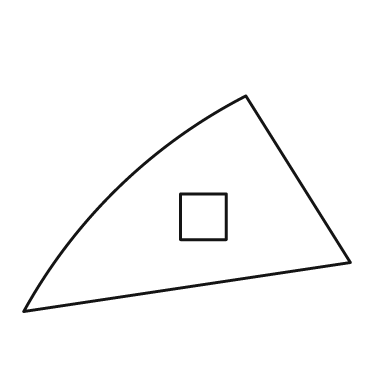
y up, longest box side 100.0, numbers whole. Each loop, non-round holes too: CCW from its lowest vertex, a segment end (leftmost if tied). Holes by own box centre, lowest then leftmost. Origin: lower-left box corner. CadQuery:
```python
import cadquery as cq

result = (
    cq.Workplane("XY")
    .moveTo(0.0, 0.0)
    .lineTo(100.0, 15.0)
    .lineTo(68.0, 66.0)
    .threePointArc((29.0, 38.0), (0.0, 0.0))
    .close()
    .moveTo(48.0, 22.0)
    .lineTo(62.0, 22.0)
    .lineTo(62.0, 36.0)
    .lineTo(48.0, 36.0)
    .close()
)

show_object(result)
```